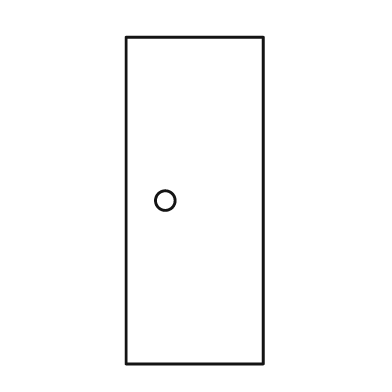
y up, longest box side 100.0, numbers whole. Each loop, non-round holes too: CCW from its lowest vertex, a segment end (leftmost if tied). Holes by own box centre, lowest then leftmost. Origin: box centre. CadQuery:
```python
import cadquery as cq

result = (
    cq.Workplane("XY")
    .moveTo(-21.0, -50.0)
    .lineTo(21.0, -50.0)
    .lineTo(21.0, 50.0)
    .lineTo(-21.0, 50.0)
    .close()
    .moveTo(-9.0, 0.0)
    .circle(3.0)
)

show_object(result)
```